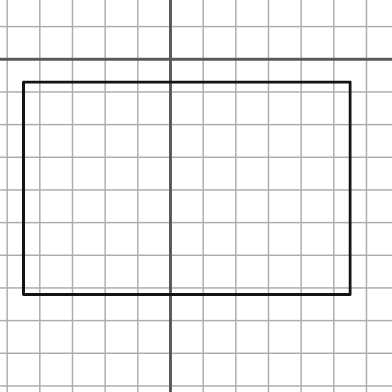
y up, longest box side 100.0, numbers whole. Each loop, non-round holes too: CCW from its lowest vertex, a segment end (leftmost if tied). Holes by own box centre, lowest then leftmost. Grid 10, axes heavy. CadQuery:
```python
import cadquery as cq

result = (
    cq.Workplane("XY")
    .moveTo(-45.0, -72.0)
    .lineTo(55.0, -72.0)
    .lineTo(55.0, -7.0)
    .lineTo(-45.0, -7.0)
    .close()
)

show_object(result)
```